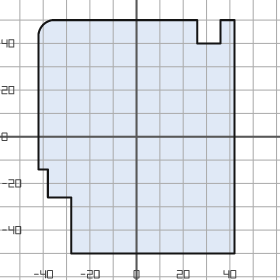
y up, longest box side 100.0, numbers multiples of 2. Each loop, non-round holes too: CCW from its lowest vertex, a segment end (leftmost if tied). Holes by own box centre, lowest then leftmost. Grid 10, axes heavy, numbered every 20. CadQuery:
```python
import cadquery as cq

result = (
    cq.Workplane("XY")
    .moveTo(-28.0, -50.0)
    .lineTo(42.0, -50.0)
    .lineTo(42.0, 50.0)
    .lineTo(36.0, 50.0)
    .lineTo(36.0, 40.0)
    .lineTo(26.0, 40.0)
    .lineTo(26.0, 50.0)
    .lineTo(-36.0, 50.0)
    .threePointArc((-40.0, 48.0), (-42.0, 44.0))
    .lineTo(-42.0, -14.0)
    .lineTo(-38.0, -14.0)
    .lineTo(-38.0, -26.0)
    .lineTo(-28.0, -26.0)
    .close()
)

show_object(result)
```